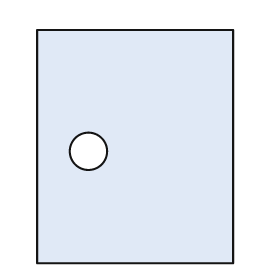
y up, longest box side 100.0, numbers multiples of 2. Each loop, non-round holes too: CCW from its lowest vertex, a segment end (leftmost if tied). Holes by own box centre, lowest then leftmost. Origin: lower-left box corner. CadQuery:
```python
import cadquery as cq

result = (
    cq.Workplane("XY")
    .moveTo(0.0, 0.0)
    .lineTo(84.0, 0.0)
    .lineTo(84.0, 100.0)
    .lineTo(0.0, 100.0)
    .close()
    .moveTo(22.0, 48.0)
    .circle(8.0)
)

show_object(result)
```